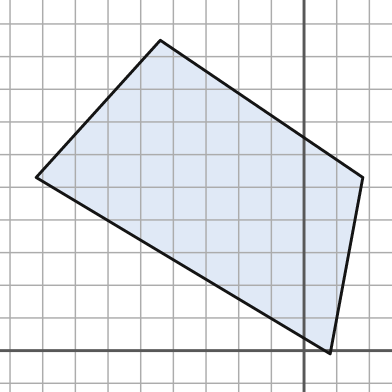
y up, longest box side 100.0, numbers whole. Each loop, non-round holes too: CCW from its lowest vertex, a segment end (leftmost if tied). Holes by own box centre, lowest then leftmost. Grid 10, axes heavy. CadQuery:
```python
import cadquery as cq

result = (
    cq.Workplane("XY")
    .moveTo(8.0, -1.0)
    .lineTo(18.0, 53.0)
    .lineTo(-44.0, 95.0)
    .lineTo(-82.0, 53.0)
    .close()
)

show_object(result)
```